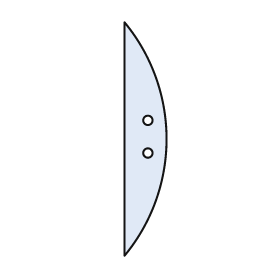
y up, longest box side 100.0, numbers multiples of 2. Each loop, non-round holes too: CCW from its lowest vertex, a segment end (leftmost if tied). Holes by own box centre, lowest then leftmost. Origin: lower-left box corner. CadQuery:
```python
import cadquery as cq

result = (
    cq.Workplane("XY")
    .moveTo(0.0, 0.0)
    .threePointArc((18.0, 50.0), (0.0, 100.0))
    .close()
    .moveTo(10.0, 44.0)
    .circle(2.0)
    .moveTo(10.0, 58.0)
    .circle(2.0)
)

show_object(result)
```